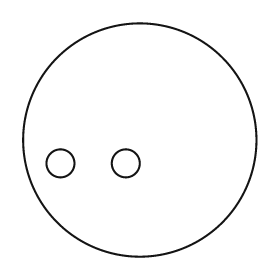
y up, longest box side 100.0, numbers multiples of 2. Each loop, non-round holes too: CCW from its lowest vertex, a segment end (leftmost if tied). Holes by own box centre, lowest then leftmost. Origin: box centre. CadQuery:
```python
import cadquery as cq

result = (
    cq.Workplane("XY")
    .moveTo(0.0, 0.0)
    .circle(50.0)
    .moveTo(-34.0, -10.0)
    .circle(6.0)
    .moveTo(-6.0, -10.0)
    .circle(6.0)
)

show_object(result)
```